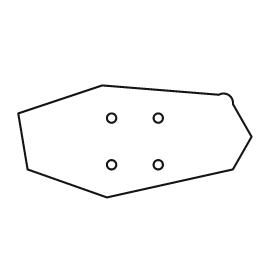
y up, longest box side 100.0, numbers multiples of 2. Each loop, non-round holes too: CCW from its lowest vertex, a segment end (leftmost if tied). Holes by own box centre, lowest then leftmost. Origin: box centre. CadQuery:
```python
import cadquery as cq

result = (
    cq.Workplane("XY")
    .moveTo(-12.0, -24.0)
    .lineTo(42.0, -12.0)
    .lineTo(50.0, 2.0)
    .lineTo(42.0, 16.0)
    .threePointArc((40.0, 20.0), (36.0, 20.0))
    .lineTo(-14.0, 24.0)
    .lineTo(-50.0, 12.0)
    .lineTo(-46.0, -12.0)
    .close()
    .moveTo(-10.0, -10.0)
    .circle(2.0)
    .moveTo(10.0, -10.0)
    .circle(2.0)
    .moveTo(-10.0, 10.0)
    .circle(2.0)
    .moveTo(10.0, 10.0)
    .circle(2.0)
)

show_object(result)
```